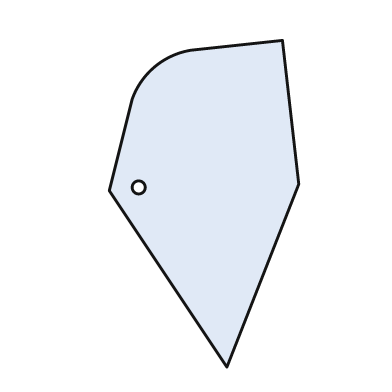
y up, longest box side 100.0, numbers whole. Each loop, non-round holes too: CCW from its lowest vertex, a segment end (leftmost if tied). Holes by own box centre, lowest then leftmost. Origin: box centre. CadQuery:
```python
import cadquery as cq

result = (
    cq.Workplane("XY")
    .moveTo(7.0, -50.0)
    .lineTo(29.0, 6.0)
    .lineTo(24.0, 50.0)
    .lineTo(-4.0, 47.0)
    .threePointArc((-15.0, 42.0), (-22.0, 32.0))
    .lineTo(-29.0, 4.0)
    .close()
    .moveTo(-20.0, 5.0)
    .circle(2.0)
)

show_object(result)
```